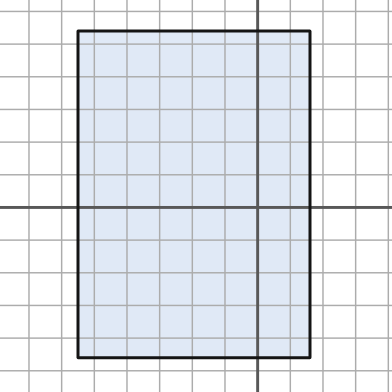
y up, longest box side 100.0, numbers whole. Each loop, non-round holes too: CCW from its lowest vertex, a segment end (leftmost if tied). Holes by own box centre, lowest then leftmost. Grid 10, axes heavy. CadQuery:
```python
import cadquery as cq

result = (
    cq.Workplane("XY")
    .moveTo(-55.0, -46.0)
    .lineTo(16.0, -46.0)
    .lineTo(16.0, 54.0)
    .lineTo(-55.0, 54.0)
    .close()
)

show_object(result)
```